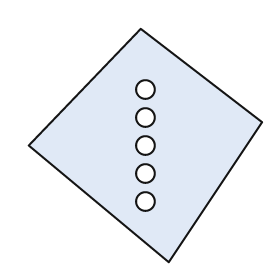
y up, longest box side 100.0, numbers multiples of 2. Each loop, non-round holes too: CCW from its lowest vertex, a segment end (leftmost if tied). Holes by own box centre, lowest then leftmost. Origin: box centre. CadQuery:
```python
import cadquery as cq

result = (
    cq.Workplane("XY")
    .moveTo(10.0, -50.0)
    .lineTo(50.0, 10.0)
    .lineTo(-2.0, 50.0)
    .lineTo(-50.0, 0.0)
    .close()
    .moveTo(0.0, -24.0)
    .circle(4.0)
    .moveTo(0.0, -12.0)
    .circle(4.0)
    .moveTo(0.0, 0.0)
    .circle(4.0)
    .moveTo(0.0, 12.0)
    .circle(4.0)
    .moveTo(0.0, 24.0)
    .circle(4.0)
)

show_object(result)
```